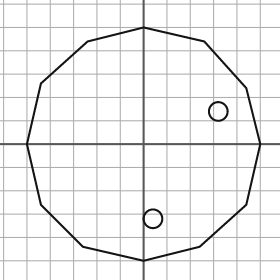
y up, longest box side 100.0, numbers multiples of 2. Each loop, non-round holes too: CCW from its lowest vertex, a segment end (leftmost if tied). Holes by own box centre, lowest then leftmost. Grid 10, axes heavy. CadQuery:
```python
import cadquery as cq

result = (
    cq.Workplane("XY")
    .moveTo(0.0, -50.0)
    .lineTo(24.0, -44.0)
    .lineTo(44.0, -26.0)
    .lineTo(50.0, 0.0)
    .lineTo(44.0, 24.0)
    .lineTo(26.0, 44.0)
    .lineTo(0.0, 50.0)
    .lineTo(-24.0, 44.0)
    .lineTo(-44.0, 26.0)
    .lineTo(-50.0, 0.0)
    .lineTo(-44.0, -26.0)
    .lineTo(-26.0, -44.0)
    .close()
    .moveTo(4.0, -32.0)
    .circle(4.0)
    .moveTo(32.0, 14.0)
    .circle(4.0)
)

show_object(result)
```